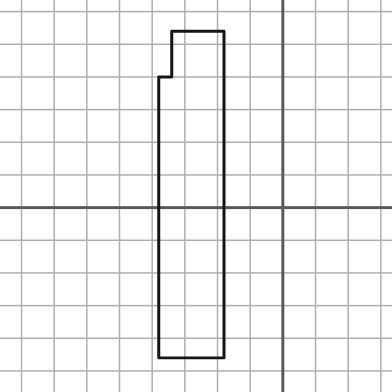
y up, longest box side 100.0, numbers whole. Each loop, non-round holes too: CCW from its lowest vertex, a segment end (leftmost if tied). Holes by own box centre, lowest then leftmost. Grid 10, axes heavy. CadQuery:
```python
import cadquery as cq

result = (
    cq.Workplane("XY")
    .moveTo(-38.0, -46.0)
    .lineTo(-18.0, -46.0)
    .lineTo(-18.0, 54.0)
    .lineTo(-34.0, 54.0)
    .lineTo(-34.0, 40.0)
    .lineTo(-38.0, 40.0)
    .close()
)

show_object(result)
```